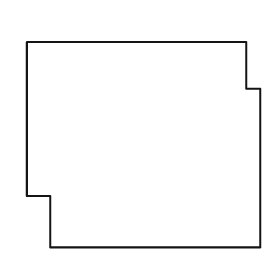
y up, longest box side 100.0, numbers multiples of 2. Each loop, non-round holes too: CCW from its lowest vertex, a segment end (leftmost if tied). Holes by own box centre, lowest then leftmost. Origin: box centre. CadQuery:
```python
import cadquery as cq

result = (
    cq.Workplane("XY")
    .moveTo(-40.0, -44.0)
    .lineTo(50.0, -44.0)
    .lineTo(50.0, 24.0)
    .lineTo(44.0, 24.0)
    .lineTo(44.0, 44.0)
    .lineTo(-50.0, 44.0)
    .lineTo(-50.0, -22.0)
    .lineTo(-40.0, -22.0)
    .close()
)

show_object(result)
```